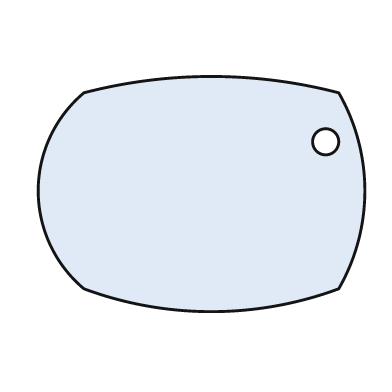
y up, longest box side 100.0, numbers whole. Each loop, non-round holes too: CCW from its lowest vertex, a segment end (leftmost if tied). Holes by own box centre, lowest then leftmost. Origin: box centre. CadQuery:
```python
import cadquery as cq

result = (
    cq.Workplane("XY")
    .moveTo(-36.0, -29.0)
    .threePointArc((3.0, -36.0), (42.0, -29.0))
    .threePointArc((50.0, 1.0), (42.0, 31.0))
    .threePointArc((3.0, 36.0), (-36.0, 31.0))
    .threePointArc((-50.0, 1.0), (-36.0, -29.0))
    .close()
    .moveTo(38.0, 16.0)
    .circle(4.0)
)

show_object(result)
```